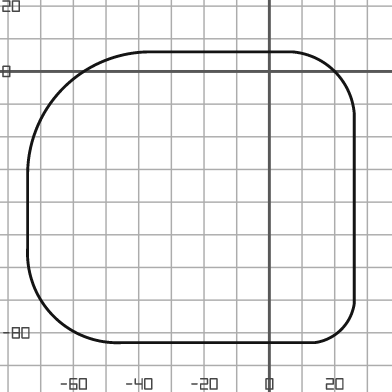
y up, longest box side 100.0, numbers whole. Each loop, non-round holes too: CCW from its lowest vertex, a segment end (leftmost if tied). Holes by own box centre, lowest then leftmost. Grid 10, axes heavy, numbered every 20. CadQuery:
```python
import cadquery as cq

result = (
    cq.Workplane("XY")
    .moveTo(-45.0, -83.0)
    .lineTo(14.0, -83.0)
    .threePointArc((22.0, -79.0), (26.0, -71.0))
    .lineTo(26.0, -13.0)
    .threePointArc((20.0, 0.0), (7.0, 6.0))
    .lineTo(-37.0, 6.0)
    .threePointArc((-63.0, -5.0), (-74.0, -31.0))
    .lineTo(-74.0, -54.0)
    .threePointArc((-66.0, -75.0), (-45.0, -83.0))
    .close()
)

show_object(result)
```